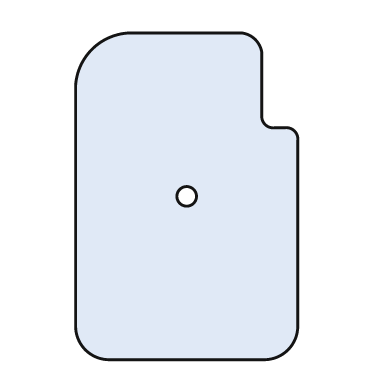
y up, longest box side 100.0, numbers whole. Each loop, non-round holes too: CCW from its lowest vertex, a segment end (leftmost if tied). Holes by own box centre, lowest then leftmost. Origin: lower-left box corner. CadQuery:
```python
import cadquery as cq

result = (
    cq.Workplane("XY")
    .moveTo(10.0, 0.0)
    .lineTo(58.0, 0.0)
    .threePointArc((65.0, 3.0), (68.0, 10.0))
    .lineTo(68.0, 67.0)
    .threePointArc((67.0, 70.0), (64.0, 71.0))
    .lineTo(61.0, 71.0)
    .threePointArc((58.0, 72.0), (57.0, 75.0))
    .lineTo(57.0, 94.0)
    .threePointArc((55.0, 98.0), (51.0, 100.0))
    .lineTo(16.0, 100.0)
    .threePointArc((5.0, 95.0), (0.0, 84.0))
    .lineTo(0.0, 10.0)
    .threePointArc((3.0, 3.0), (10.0, 0.0))
    .close()
    .moveTo(34.0, 50.0)
    .circle(3.0)
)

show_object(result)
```